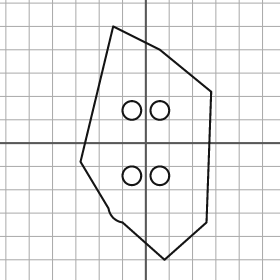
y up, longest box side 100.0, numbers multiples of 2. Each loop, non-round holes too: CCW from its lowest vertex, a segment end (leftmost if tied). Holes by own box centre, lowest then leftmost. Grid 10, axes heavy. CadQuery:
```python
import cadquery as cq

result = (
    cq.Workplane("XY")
    .moveTo(8.0, -50.0)
    .lineTo(26.0, -34.0)
    .lineTo(28.0, 22.0)
    .lineTo(6.0, 40.0)
    .lineTo(-14.0, 50.0)
    .lineTo(-28.0, -8.0)
    .lineTo(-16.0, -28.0)
    .threePointArc((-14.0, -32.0), (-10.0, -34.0))
    .close()
    .moveTo(-6.0, -14.0)
    .circle(4.0)
    .moveTo(6.0, -14.0)
    .circle(4.0)
    .moveTo(-6.0, 14.0)
    .circle(4.0)
    .moveTo(6.0, 14.0)
    .circle(4.0)
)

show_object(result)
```